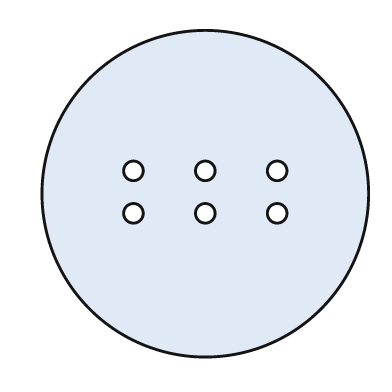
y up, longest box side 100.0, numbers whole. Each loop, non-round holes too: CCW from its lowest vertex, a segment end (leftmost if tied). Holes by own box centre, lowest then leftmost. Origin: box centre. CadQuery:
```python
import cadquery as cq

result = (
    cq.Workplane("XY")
    .moveTo(0.0, 0.0)
    .circle(50.0)
    .moveTo(-22.0, -6.0)
    .circle(3.0)
    .moveTo(0.0, -6.0)
    .circle(3.0)
    .moveTo(22.0, -6.0)
    .circle(3.0)
    .moveTo(-22.0, 7.0)
    .circle(3.0)
    .moveTo(0.0, 7.0)
    .circle(3.0)
    .moveTo(22.0, 7.0)
    .circle(3.0)
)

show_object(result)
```